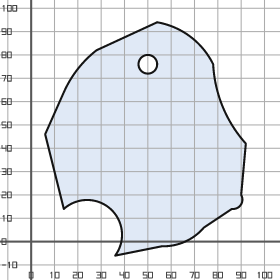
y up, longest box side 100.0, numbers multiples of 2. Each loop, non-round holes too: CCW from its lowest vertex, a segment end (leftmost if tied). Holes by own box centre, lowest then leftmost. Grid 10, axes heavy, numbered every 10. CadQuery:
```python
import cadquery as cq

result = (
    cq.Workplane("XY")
    .moveTo(36.0, -6.0)
    .lineTo(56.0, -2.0)
    .threePointArc((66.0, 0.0), (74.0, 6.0))
    .lineTo(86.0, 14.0)
    .threePointArc((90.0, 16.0), (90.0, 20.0))
    .lineTo(92.0, 42.0)
    .threePointArc((82.0, 58.0), (78.0, 76.0))
    .threePointArc((68.0, 88.0), (54.0, 94.0))
    .lineTo(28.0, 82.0)
    .threePointArc((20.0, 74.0), (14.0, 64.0))
    .lineTo(6.0, 46.0)
    .lineTo(14.0, 14.0)
    .threePointArc((34.0, 14.0), (36.0, -6.0))
    .close()
    .moveTo(50.0, 76.0)
    .circle(4.0)
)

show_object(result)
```